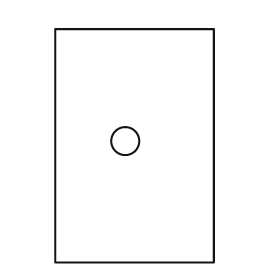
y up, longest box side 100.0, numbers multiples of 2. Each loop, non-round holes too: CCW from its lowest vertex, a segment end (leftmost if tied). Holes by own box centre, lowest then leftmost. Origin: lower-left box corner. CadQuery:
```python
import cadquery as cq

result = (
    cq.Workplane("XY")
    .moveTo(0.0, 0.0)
    .lineTo(68.0, 0.0)
    .lineTo(68.0, 100.0)
    .lineTo(0.0, 100.0)
    .close()
    .moveTo(30.0, 52.0)
    .circle(6.0)
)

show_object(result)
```